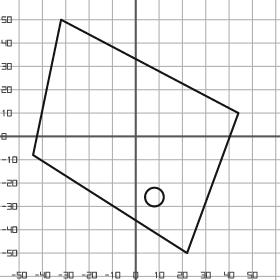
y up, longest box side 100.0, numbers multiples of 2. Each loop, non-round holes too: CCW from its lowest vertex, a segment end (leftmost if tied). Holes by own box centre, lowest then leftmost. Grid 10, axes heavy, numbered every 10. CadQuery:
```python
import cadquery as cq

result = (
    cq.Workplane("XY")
    .moveTo(22.0, -50.0)
    .lineTo(44.0, 10.0)
    .lineTo(-32.0, 50.0)
    .lineTo(-44.0, -8.0)
    .close()
    .moveTo(8.0, -26.0)
    .circle(4.0)
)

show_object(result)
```